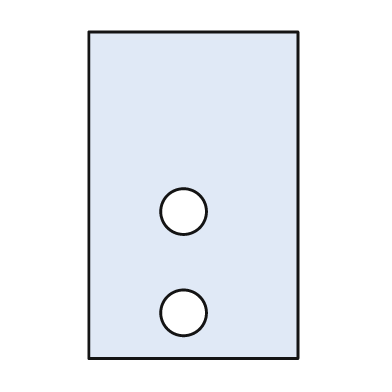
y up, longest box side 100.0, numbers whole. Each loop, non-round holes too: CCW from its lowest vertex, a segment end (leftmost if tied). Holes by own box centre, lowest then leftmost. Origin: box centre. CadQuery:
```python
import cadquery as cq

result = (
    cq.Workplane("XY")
    .moveTo(-32.0, -50.0)
    .lineTo(32.0, -50.0)
    .lineTo(32.0, 50.0)
    .lineTo(-32.0, 50.0)
    .close()
    .moveTo(-3.0, -36.0)
    .circle(7.0)
    .moveTo(-3.0, -5.0)
    .circle(7.0)
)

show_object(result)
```